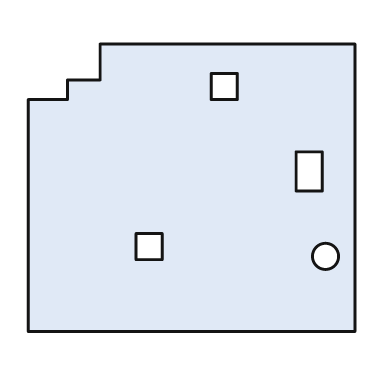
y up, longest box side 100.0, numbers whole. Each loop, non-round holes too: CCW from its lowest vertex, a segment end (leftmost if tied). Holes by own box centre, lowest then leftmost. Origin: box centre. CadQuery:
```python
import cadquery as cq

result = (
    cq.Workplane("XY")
    .moveTo(-50.0, -44.0)
    .lineTo(50.0, -44.0)
    .lineTo(50.0, 44.0)
    .lineTo(-28.0, 44.0)
    .lineTo(-28.0, 33.0)
    .lineTo(-38.0, 33.0)
    .lineTo(-38.0, 27.0)
    .lineTo(-50.0, 27.0)
    .close()
    .moveTo(41.0, -21.0)
    .circle(4.0)
    .moveTo(-17.0, -22.0)
    .lineTo(-9.0, -22.0)
    .lineTo(-9.0, -14.0)
    .lineTo(-17.0, -14.0)
    .close()
    .moveTo(32.0, -1.0)
    .lineTo(40.0, -1.0)
    .lineTo(40.0, 11.0)
    .lineTo(32.0, 11.0)
    .close()
    .moveTo(6.0, 27.0)
    .lineTo(14.0, 27.0)
    .lineTo(14.0, 35.0)
    .lineTo(6.0, 35.0)
    .close()
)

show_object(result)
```